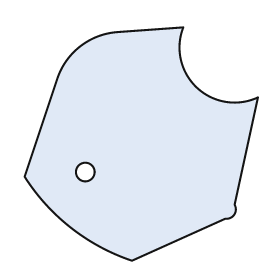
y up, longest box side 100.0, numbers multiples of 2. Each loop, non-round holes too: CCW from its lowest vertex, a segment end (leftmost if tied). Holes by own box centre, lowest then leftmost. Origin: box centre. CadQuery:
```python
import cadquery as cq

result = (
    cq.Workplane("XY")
    .moveTo(-4.0, -50.0)
    .lineTo(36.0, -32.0)
    .threePointArc((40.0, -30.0), (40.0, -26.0))
    .lineTo(50.0, 20.0)
    .threePointArc((24.0, 24.0), (18.0, 50.0))
    .lineTo(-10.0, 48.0)
    .threePointArc((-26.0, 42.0), (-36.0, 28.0))
    .lineTo(-50.0, -14.0)
    .threePointArc((-30.0, -36.0), (-4.0, -50.0))
    .close()
    .moveTo(-24.0, -12.0)
    .circle(4.0)
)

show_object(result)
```